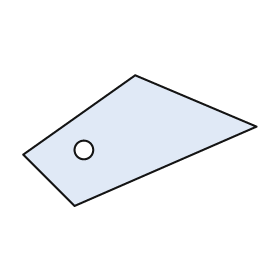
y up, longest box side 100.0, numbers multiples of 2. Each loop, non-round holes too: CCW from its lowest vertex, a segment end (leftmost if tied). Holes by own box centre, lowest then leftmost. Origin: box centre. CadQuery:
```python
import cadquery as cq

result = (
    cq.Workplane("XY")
    .moveTo(-28.0, -28.0)
    .lineTo(50.0, 6.0)
    .lineTo(-2.0, 28.0)
    .lineTo(-50.0, -6.0)
    .close()
    .moveTo(-24.0, -4.0)
    .circle(4.0)
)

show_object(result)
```